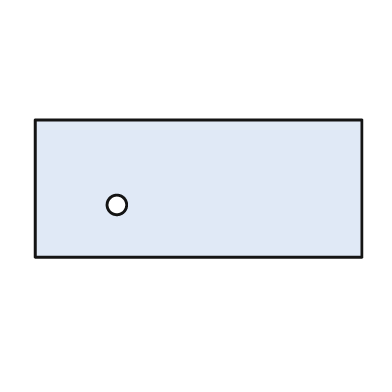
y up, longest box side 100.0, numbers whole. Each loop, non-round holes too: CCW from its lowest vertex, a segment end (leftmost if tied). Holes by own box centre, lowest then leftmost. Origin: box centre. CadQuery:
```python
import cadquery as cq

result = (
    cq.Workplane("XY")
    .moveTo(-50.0, -21.0)
    .lineTo(50.0, -21.0)
    .lineTo(50.0, 21.0)
    .lineTo(-50.0, 21.0)
    .close()
    .moveTo(-25.0, -5.0)
    .circle(3.0)
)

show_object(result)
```